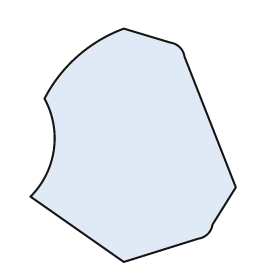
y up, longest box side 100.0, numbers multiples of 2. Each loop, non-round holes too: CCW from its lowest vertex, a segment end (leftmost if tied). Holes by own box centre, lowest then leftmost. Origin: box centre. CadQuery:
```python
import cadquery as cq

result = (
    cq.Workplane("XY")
    .moveTo(-4.0, -50.0)
    .lineTo(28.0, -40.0)
    .threePointArc((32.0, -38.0), (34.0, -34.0))
    .lineTo(44.0, -18.0)
    .lineTo(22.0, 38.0)
    .threePointArc((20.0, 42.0), (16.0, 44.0))
    .lineTo(-4.0, 50.0)
    .threePointArc((-24.0, 38.0), (-38.0, 20.0))
    .threePointArc((-34.0, -2.0), (-44.0, -22.0))
    .close()
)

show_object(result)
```